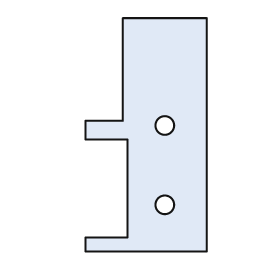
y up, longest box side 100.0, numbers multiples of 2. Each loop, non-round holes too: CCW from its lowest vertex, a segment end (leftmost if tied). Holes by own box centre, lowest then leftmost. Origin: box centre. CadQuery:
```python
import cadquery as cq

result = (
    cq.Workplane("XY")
    .moveTo(-26.0, -50.0)
    .lineTo(26.0, -50.0)
    .lineTo(26.0, 50.0)
    .lineTo(-10.0, 50.0)
    .lineTo(-10.0, 6.0)
    .lineTo(-26.0, 6.0)
    .lineTo(-26.0, -2.0)
    .lineTo(-8.0, -2.0)
    .lineTo(-8.0, -44.0)
    .lineTo(-26.0, -44.0)
    .close()
    .moveTo(8.0, -30.0)
    .circle(4.0)
    .moveTo(8.0, 4.0)
    .circle(4.0)
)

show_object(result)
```